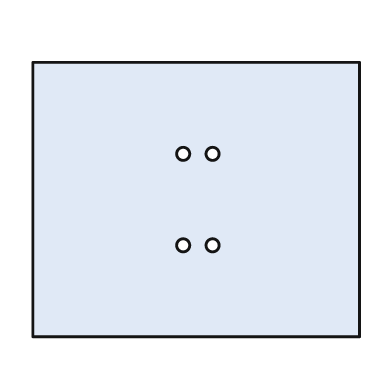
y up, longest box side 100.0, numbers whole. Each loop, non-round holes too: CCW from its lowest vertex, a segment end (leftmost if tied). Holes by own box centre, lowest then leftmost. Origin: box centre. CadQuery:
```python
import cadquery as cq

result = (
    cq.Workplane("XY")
    .moveTo(-50.0, -42.0)
    .lineTo(50.0, -42.0)
    .lineTo(50.0, 42.0)
    .lineTo(-50.0, 42.0)
    .close()
    .moveTo(-4.0, -14.0)
    .circle(2.0)
    .moveTo(5.0, -14.0)
    .circle(2.0)
    .moveTo(-4.0, 14.0)
    .circle(2.0)
    .moveTo(5.0, 14.0)
    .circle(2.0)
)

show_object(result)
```